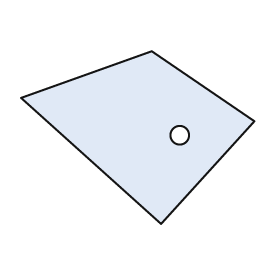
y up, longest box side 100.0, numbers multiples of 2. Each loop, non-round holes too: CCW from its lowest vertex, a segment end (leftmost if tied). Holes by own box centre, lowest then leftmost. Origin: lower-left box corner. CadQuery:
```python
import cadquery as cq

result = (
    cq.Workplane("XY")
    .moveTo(60.0, 0.0)
    .lineTo(100.0, 44.0)
    .lineTo(56.0, 74.0)
    .lineTo(0.0, 54.0)
    .close()
    .moveTo(68.0, 38.0)
    .circle(4.0)
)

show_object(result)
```